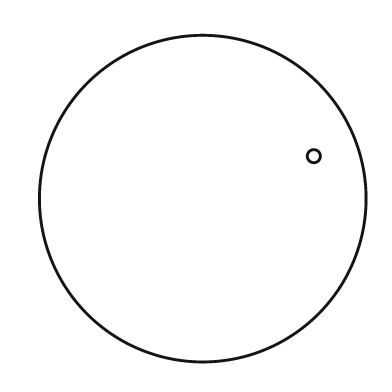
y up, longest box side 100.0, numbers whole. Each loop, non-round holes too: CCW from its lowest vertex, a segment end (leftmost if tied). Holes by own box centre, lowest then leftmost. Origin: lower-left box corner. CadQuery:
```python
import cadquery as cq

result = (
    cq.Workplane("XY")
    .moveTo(50.0, 50.0)
    .circle(50.0)
    .moveTo(84.0, 63.0)
    .circle(2.0)
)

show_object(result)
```